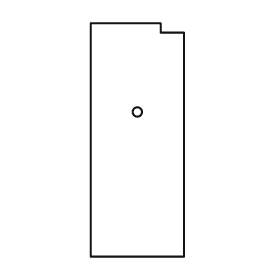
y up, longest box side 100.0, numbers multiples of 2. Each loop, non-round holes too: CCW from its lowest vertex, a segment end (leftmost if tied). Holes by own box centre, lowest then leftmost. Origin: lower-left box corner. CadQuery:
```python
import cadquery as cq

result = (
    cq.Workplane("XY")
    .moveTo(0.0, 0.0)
    .lineTo(40.0, 0.0)
    .lineTo(40.0, 96.0)
    .lineTo(30.0, 96.0)
    .lineTo(30.0, 100.0)
    .lineTo(0.0, 100.0)
    .close()
    .moveTo(20.0, 62.0)
    .circle(2.0)
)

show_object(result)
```